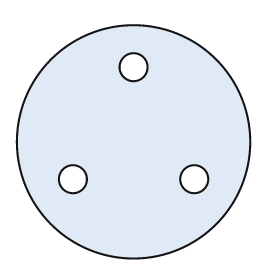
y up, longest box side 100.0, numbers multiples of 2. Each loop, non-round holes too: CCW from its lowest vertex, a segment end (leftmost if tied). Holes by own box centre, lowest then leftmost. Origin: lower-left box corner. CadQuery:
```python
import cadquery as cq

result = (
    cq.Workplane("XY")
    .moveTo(50.0, 50.0)
    .circle(50.0)
    .moveTo(24.0, 34.0)
    .circle(6.0)
    .moveTo(76.0, 34.0)
    .circle(6.0)
    .moveTo(50.0, 82.0)
    .circle(6.0)
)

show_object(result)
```